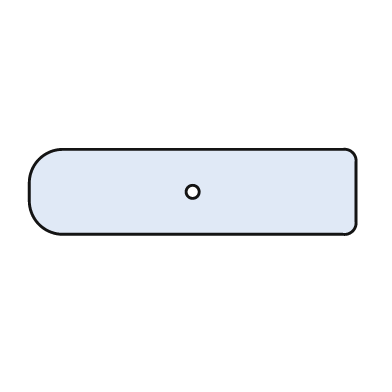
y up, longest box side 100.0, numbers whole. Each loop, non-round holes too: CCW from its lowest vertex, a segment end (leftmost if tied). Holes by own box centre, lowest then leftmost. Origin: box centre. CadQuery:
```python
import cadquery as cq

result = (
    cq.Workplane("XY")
    .moveTo(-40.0, -13.0)
    .lineTo(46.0, -13.0)
    .threePointArc((49.0, -12.0), (50.0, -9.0))
    .lineTo(50.0, 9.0)
    .threePointArc((49.0, 12.0), (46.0, 13.0))
    .lineTo(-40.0, 13.0)
    .threePointArc((-47.0, 10.0), (-50.0, 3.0))
    .lineTo(-50.0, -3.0)
    .threePointArc((-47.0, -10.0), (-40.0, -13.0))
    .close()
    .moveTo(0.0, 0.0)
    .circle(2.0)
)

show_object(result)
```